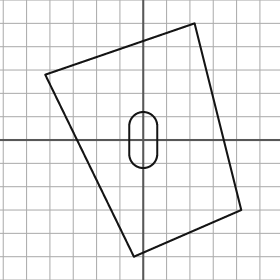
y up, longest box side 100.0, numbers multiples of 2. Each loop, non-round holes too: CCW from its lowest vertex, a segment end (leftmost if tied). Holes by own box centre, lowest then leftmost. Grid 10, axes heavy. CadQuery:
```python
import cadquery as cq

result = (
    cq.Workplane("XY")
    .moveTo(-4.0, -50.0)
    .lineTo(42.0, -30.0)
    .lineTo(22.0, 50.0)
    .lineTo(-42.0, 28.0)
    .close()
    .moveTo(-6.0, -6.0)
    .threePointArc((0.0, -12.0), (6.0, -6.0))
    .lineTo(6.0, 6.0)
    .threePointArc((0.0, 12.0), (-6.0, 6.0))
    .close()
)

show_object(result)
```